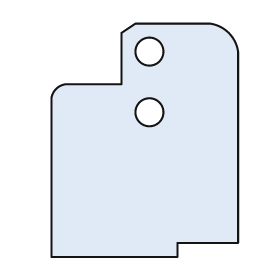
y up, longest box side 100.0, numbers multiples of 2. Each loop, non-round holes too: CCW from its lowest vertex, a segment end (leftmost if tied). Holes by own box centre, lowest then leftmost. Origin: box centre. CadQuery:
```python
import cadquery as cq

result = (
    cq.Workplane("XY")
    .moveTo(-40.0, -50.0)
    .lineTo(14.0, -50.0)
    .lineTo(14.0, -44.0)
    .lineTo(40.0, -44.0)
    .lineTo(40.0, 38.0)
    .threePointArc((36.0, 46.0), (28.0, 50.0))
    .lineTo(-4.0, 50.0)
    .lineTo(-10.0, 46.0)
    .lineTo(-10.0, 24.0)
    .lineTo(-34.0, 24.0)
    .threePointArc((-38.0, 22.0), (-40.0, 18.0))
    .close()
    .moveTo(2.0, 12.0)
    .circle(6.0)
    .moveTo(2.0, 38.0)
    .circle(6.0)
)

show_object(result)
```